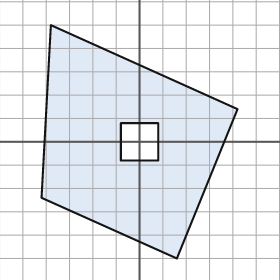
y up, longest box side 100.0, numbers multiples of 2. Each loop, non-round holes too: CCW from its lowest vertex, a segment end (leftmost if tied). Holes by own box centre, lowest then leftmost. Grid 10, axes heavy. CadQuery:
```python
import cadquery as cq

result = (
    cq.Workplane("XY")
    .moveTo(16.0, -50.0)
    .lineTo(42.0, 14.0)
    .lineTo(-38.0, 50.0)
    .lineTo(-42.0, -24.0)
    .close()
    .moveTo(-8.0, -8.0)
    .lineTo(8.0, -8.0)
    .lineTo(8.0, 8.0)
    .lineTo(-8.0, 8.0)
    .close()
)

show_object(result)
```